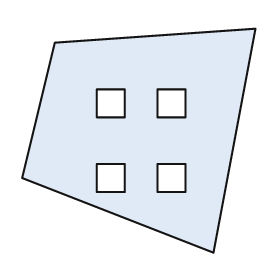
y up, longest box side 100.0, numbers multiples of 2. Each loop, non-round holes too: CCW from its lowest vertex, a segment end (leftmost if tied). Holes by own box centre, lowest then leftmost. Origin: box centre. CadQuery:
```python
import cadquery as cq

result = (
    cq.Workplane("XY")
    .moveTo(32.0, -48.0)
    .lineTo(50.0, 48.0)
    .lineTo(-36.0, 42.0)
    .lineTo(-50.0, -16.0)
    .close()
    .moveTo(-18.0, -22.0)
    .lineTo(-6.0, -22.0)
    .lineTo(-6.0, -10.0)
    .lineTo(-18.0, -10.0)
    .close()
    .moveTo(8.0, -22.0)
    .lineTo(20.0, -22.0)
    .lineTo(20.0, -10.0)
    .lineTo(8.0, -10.0)
    .close()
    .moveTo(-18.0, 10.0)
    .lineTo(-6.0, 10.0)
    .lineTo(-6.0, 22.0)
    .lineTo(-18.0, 22.0)
    .close()
    .moveTo(8.0, 10.0)
    .lineTo(20.0, 10.0)
    .lineTo(20.0, 22.0)
    .lineTo(8.0, 22.0)
    .close()
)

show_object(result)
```